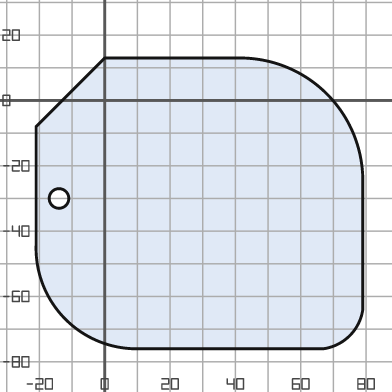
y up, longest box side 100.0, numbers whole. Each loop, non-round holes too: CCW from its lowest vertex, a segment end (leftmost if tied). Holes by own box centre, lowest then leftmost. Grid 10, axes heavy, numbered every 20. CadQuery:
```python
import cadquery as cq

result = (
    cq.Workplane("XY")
    .moveTo(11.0, -76.0)
    .lineTo(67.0, -76.0)
    .threePointArc((75.0, -72.0), (79.0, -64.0))
    .lineTo(79.0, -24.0)
    .threePointArc((68.0, 2.0), (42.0, 13.0))
    .lineTo(0.0, 13.0)
    .lineTo(-21.0, -8.0)
    .lineTo(-21.0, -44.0)
    .threePointArc((-12.0, -67.0), (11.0, -76.0))
    .close()
    .moveTo(-14.0, -30.0)
    .circle(3.0)
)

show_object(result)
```